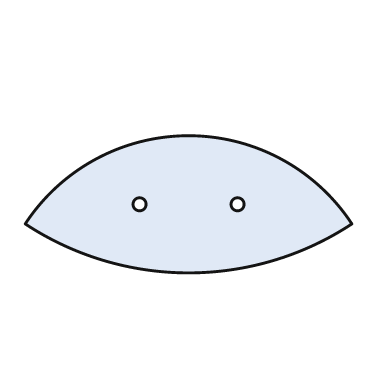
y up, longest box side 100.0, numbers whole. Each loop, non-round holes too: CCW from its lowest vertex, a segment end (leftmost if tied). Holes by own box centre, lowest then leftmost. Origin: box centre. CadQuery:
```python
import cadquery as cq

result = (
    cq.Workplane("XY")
    .moveTo(-50.0, -6.0)
    .threePointArc((0.0, -21.0), (50.0, -6.0))
    .threePointArc((0.0, 21.0), (-50.0, -6.0))
    .close()
    .moveTo(-15.0, 0.0)
    .circle(2.0)
    .moveTo(15.0, 0.0)
    .circle(2.0)
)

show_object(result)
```